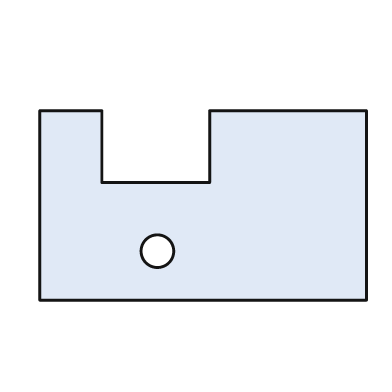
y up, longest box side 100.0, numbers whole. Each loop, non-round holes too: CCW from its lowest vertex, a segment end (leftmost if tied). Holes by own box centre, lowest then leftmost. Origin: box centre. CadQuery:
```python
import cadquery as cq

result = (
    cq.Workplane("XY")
    .moveTo(-50.0, -29.0)
    .lineTo(50.0, -29.0)
    .lineTo(50.0, 29.0)
    .lineTo(2.0, 29.0)
    .lineTo(2.0, 7.0)
    .lineTo(-31.0, 7.0)
    .lineTo(-31.0, 29.0)
    .lineTo(-50.0, 29.0)
    .close()
    .moveTo(-14.0, -14.0)
    .circle(5.0)
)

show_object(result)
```